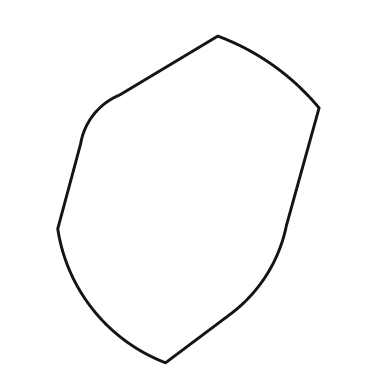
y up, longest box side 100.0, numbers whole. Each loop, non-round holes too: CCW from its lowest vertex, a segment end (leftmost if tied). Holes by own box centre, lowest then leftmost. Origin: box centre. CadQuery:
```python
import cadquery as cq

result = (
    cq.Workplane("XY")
    .moveTo(-7.0, -50.0)
    .lineTo(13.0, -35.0)
    .threePointArc((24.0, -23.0), (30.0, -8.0))
    .lineTo(40.0, 28.0)
    .threePointArc((26.0, 41.0), (9.0, 50.0))
    .lineTo(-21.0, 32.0)
    .threePointArc((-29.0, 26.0), (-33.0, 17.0))
    .lineTo(-40.0, -9.0)
    .threePointArc((-29.0, -34.0), (-7.0, -50.0))
    .close()
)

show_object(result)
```